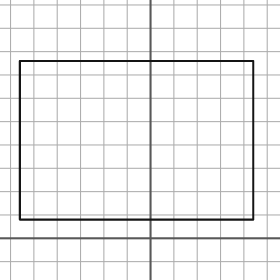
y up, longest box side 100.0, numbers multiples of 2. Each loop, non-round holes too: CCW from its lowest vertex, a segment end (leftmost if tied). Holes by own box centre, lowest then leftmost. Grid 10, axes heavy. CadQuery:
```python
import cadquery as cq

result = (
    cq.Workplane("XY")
    .moveTo(-56.0, 8.0)
    .lineTo(44.0, 8.0)
    .lineTo(44.0, 76.0)
    .lineTo(-56.0, 76.0)
    .close()
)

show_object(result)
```